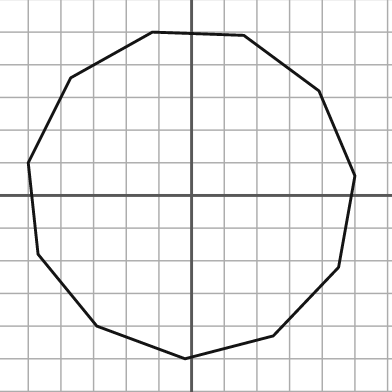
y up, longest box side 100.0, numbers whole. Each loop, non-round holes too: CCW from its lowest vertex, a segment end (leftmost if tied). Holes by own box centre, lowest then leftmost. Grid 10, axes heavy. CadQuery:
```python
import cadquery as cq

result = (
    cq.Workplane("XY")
    .moveTo(-2.0, -50.0)
    .lineTo(25.0, -43.0)
    .lineTo(45.0, -22.0)
    .lineTo(50.0, 6.0)
    .lineTo(39.0, 32.0)
    .lineTo(16.0, 49.0)
    .lineTo(-12.0, 50.0)
    .lineTo(-37.0, 36.0)
    .lineTo(-50.0, 10.0)
    .lineTo(-47.0, -18.0)
    .lineTo(-29.0, -40.0)
    .close()
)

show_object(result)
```